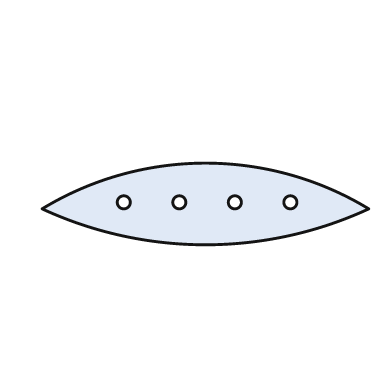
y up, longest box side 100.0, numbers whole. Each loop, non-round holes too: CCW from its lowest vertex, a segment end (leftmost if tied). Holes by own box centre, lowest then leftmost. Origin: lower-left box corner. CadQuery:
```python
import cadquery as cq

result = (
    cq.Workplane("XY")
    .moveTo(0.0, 11.0)
    .threePointArc((50.0, 0.0), (100.0, 11.0))
    .threePointArc((50.0, 25.0), (0.0, 11.0))
    .close()
    .moveTo(25.0, 13.0)
    .circle(2.0)
    .moveTo(42.0, 13.0)
    .circle(2.0)
    .moveTo(59.0, 13.0)
    .circle(2.0)
    .moveTo(76.0, 13.0)
    .circle(2.0)
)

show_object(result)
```